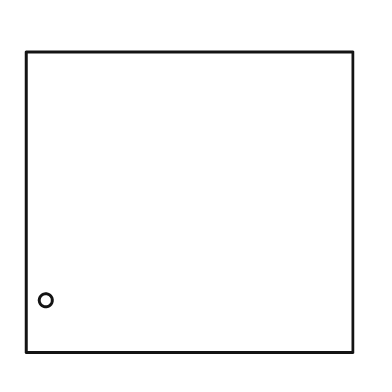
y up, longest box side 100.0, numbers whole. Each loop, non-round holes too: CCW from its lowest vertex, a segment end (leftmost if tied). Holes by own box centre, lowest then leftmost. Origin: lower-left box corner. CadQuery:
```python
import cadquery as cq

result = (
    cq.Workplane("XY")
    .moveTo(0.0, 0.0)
    .lineTo(100.0, 0.0)
    .lineTo(100.0, 92.0)
    .lineTo(0.0, 92.0)
    .close()
    .moveTo(6.0, 16.0)
    .circle(2.0)
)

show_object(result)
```